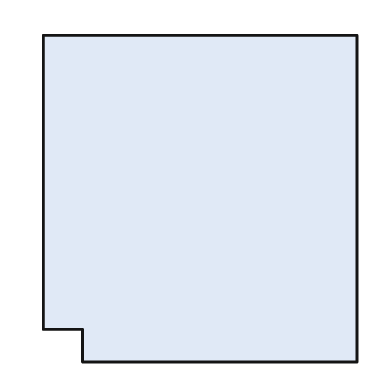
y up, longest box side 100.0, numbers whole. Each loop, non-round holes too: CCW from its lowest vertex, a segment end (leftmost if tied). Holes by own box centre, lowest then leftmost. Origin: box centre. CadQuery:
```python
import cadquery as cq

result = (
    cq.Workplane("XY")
    .moveTo(-36.0, -50.0)
    .lineTo(48.0, -50.0)
    .lineTo(48.0, 50.0)
    .lineTo(-48.0, 50.0)
    .lineTo(-48.0, -40.0)
    .lineTo(-36.0, -40.0)
    .close()
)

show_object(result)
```